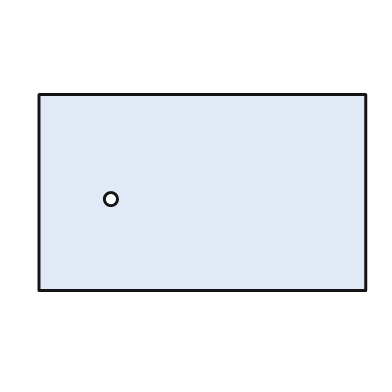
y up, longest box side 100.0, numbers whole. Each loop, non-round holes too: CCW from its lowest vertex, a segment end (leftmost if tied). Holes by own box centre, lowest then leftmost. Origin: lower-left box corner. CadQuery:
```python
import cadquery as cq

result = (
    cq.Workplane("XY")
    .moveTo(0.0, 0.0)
    .lineTo(100.0, 0.0)
    .lineTo(100.0, 60.0)
    .lineTo(0.0, 60.0)
    .close()
    .moveTo(22.0, 28.0)
    .circle(2.0)
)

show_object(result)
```